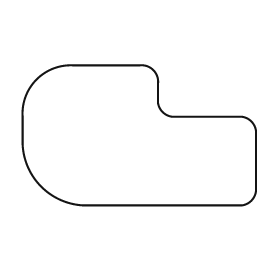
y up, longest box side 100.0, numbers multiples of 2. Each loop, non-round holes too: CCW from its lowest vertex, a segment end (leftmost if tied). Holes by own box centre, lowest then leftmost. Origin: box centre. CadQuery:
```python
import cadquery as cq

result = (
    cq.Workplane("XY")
    .moveTo(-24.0, -30.0)
    .lineTo(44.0, -30.0)
    .threePointArc((48.0, -28.0), (50.0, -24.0))
    .lineTo(50.0, 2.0)
    .threePointArc((48.0, 6.0), (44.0, 8.0))
    .lineTo(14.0, 8.0)
    .threePointArc((10.0, 10.0), (8.0, 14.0))
    .lineTo(8.0, 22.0)
    .threePointArc((6.0, 28.0), (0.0, 30.0))
    .lineTo(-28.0, 30.0)
    .threePointArc((-44.0, 24.0), (-50.0, 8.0))
    .lineTo(-50.0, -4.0)
    .threePointArc((-42.0, -22.0), (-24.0, -30.0))
    .close()
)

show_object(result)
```